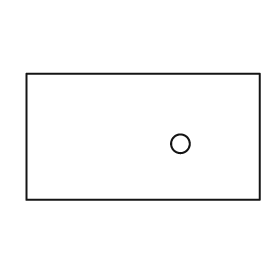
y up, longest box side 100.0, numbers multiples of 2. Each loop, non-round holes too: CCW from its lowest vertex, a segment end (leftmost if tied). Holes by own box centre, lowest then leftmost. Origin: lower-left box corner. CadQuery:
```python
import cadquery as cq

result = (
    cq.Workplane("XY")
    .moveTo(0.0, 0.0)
    .lineTo(100.0, 0.0)
    .lineTo(100.0, 54.0)
    .lineTo(0.0, 54.0)
    .close()
    .moveTo(66.0, 24.0)
    .circle(4.0)
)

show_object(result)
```